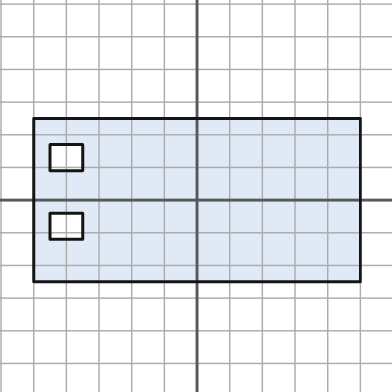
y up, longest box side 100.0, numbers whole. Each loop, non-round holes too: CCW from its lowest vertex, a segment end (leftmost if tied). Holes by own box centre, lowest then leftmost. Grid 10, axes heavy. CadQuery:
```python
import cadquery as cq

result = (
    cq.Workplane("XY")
    .moveTo(-50.0, -25.0)
    .lineTo(50.0, -25.0)
    .lineTo(50.0, 25.0)
    .lineTo(-50.0, 25.0)
    .close()
    .moveTo(-45.0, -12.0)
    .lineTo(-35.0, -12.0)
    .lineTo(-35.0, -4.0)
    .lineTo(-45.0, -4.0)
    .close()
    .moveTo(-45.0, 9.0)
    .lineTo(-35.0, 9.0)
    .lineTo(-35.0, 17.0)
    .lineTo(-45.0, 17.0)
    .close()
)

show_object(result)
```